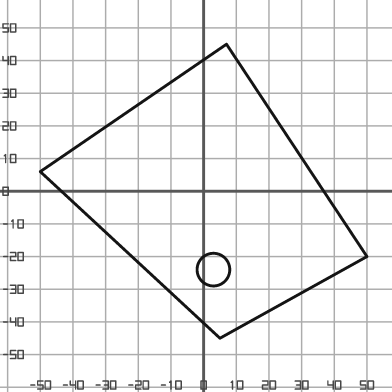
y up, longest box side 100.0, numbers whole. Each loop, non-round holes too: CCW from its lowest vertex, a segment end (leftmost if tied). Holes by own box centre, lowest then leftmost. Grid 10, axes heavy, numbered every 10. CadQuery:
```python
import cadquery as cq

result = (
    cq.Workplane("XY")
    .moveTo(5.0, -45.0)
    .lineTo(50.0, -20.0)
    .lineTo(7.0, 45.0)
    .lineTo(-50.0, 6.0)
    .close()
    .moveTo(3.0, -24.0)
    .circle(5.0)
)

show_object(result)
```